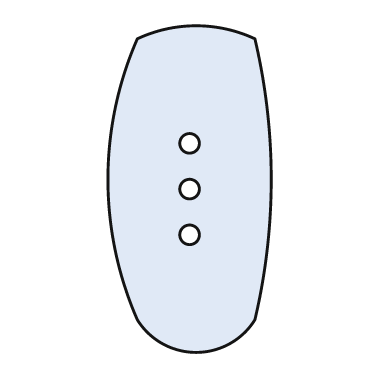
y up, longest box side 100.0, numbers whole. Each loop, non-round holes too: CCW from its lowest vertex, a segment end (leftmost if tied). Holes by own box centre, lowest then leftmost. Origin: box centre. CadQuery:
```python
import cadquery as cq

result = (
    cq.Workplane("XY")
    .moveTo(-16.0, -40.0)
    .threePointArc((2.0, -50.0), (20.0, -40.0))
    .threePointArc((25.0, 3.0), (20.0, 46.0))
    .threePointArc((2.0, 50.0), (-16.0, 46.0))
    .threePointArc((-25.0, 3.0), (-16.0, -40.0))
    .close()
    .moveTo(0.0, -14.0)
    .circle(3.0)
    .moveTo(0.0, 0.0)
    .circle(3.0)
    .moveTo(0.0, 14.0)
    .circle(3.0)
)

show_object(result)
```